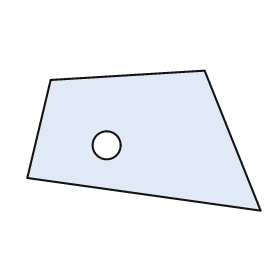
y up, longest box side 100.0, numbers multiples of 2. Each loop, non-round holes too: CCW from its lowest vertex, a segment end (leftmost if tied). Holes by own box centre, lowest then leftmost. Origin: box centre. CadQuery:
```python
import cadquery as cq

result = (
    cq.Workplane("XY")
    .moveTo(50.0, -30.0)
    .lineTo(26.0, 30.0)
    .lineTo(-40.0, 26.0)
    .lineTo(-50.0, -16.0)
    .close()
    .moveTo(-16.0, -2.0)
    .circle(6.0)
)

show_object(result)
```